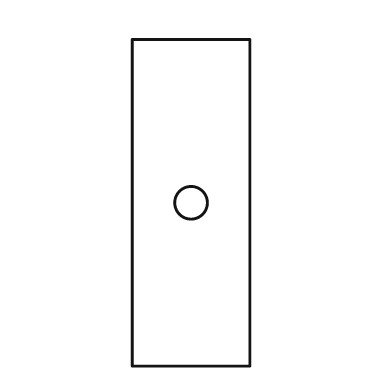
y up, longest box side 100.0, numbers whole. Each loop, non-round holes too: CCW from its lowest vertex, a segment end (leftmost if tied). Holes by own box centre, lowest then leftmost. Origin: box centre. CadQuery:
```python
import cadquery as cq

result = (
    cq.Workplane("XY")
    .moveTo(-18.0, -50.0)
    .lineTo(18.0, -50.0)
    .lineTo(18.0, 50.0)
    .lineTo(-18.0, 50.0)
    .close()
    .moveTo(0.0, 0.0)
    .circle(5.0)
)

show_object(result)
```